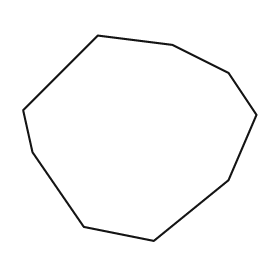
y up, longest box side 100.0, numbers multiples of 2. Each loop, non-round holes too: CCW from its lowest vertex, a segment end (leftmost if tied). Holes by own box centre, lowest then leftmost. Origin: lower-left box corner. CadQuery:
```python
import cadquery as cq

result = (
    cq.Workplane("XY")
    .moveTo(56.0, 0.0)
    .lineTo(88.0, 26.0)
    .lineTo(100.0, 54.0)
    .lineTo(88.0, 72.0)
    .lineTo(64.0, 84.0)
    .lineTo(32.0, 88.0)
    .lineTo(0.0, 56.0)
    .lineTo(4.0, 38.0)
    .lineTo(26.0, 6.0)
    .close()
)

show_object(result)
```